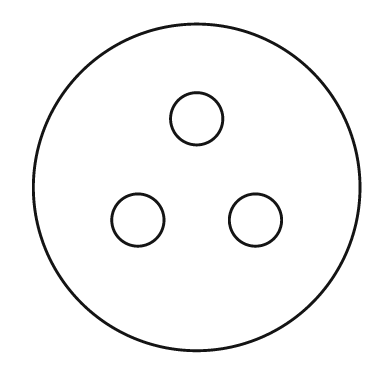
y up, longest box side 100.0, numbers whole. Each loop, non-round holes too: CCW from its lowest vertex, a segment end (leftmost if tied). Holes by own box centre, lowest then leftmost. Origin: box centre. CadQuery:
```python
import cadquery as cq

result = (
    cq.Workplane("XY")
    .moveTo(0.0, 0.0)
    .circle(50.0)
    .moveTo(-18.0, -10.0)
    .circle(8.0)
    .moveTo(18.0, -10.0)
    .circle(8.0)
    .moveTo(0.0, 21.0)
    .circle(8.0)
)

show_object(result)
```